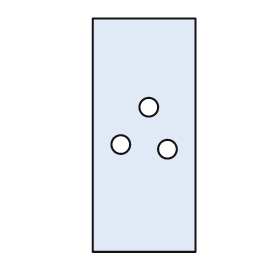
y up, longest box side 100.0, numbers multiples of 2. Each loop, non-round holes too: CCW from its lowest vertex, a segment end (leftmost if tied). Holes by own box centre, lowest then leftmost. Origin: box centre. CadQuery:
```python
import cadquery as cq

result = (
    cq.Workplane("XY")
    .moveTo(-22.0, -50.0)
    .lineTo(22.0, -50.0)
    .lineTo(22.0, 50.0)
    .lineTo(-22.0, 50.0)
    .close()
    .moveTo(10.0, -6.0)
    .circle(4.0)
    .moveTo(-10.0, -4.0)
    .circle(4.0)
    .moveTo(2.0, 12.0)
    .circle(4.0)
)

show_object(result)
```